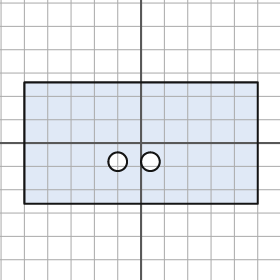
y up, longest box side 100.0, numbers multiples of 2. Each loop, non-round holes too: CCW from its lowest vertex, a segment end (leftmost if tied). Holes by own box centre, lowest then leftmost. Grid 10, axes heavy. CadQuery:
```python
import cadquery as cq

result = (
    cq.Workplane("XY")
    .moveTo(-50.0, -26.0)
    .lineTo(50.0, -26.0)
    .lineTo(50.0, 26.0)
    .lineTo(-50.0, 26.0)
    .close()
    .moveTo(-10.0, -8.0)
    .circle(4.0)
    .moveTo(4.0, -8.0)
    .circle(4.0)
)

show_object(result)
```